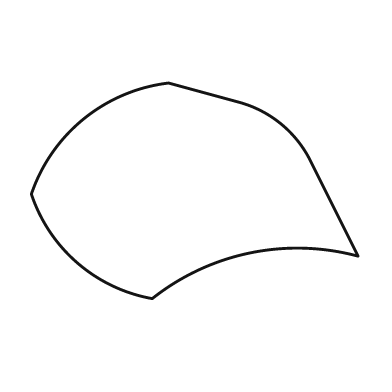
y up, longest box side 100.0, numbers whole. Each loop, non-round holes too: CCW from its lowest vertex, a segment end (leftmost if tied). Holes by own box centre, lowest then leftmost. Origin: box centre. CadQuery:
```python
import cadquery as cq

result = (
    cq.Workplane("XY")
    .moveTo(-13.0, -33.0)
    .threePointArc((17.0, -19.0), (50.0, -20.0))
    .lineTo(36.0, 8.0)
    .threePointArc((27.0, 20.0), (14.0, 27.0))
    .lineTo(-8.0, 33.0)
    .threePointArc((-34.0, 22.0), (-50.0, -1.0))
    .threePointArc((-36.0, -22.0), (-13.0, -33.0))
    .close()
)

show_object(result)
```